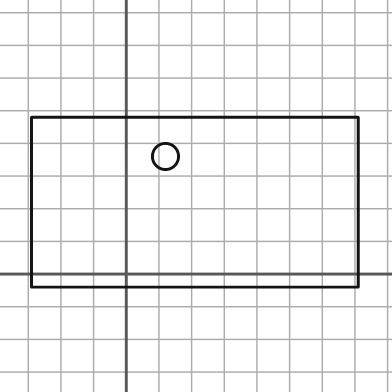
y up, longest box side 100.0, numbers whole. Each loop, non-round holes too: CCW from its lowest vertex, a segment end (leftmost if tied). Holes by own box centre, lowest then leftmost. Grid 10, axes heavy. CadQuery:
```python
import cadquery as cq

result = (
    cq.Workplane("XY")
    .moveTo(-29.0, -4.0)
    .lineTo(71.0, -4.0)
    .lineTo(71.0, 48.0)
    .lineTo(-29.0, 48.0)
    .close()
    .moveTo(12.0, 36.0)
    .circle(4.0)
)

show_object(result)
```